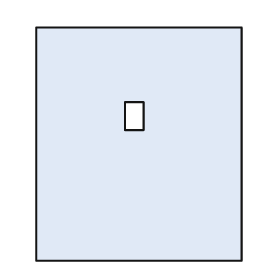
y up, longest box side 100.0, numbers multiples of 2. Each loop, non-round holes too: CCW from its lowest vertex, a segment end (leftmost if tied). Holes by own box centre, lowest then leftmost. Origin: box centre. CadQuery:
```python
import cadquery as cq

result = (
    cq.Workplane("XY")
    .moveTo(-44.0, -50.0)
    .lineTo(44.0, -50.0)
    .lineTo(44.0, 50.0)
    .lineTo(-44.0, 50.0)
    .close()
    .moveTo(-6.0, 6.0)
    .lineTo(2.0, 6.0)
    .lineTo(2.0, 18.0)
    .lineTo(-6.0, 18.0)
    .close()
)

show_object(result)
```